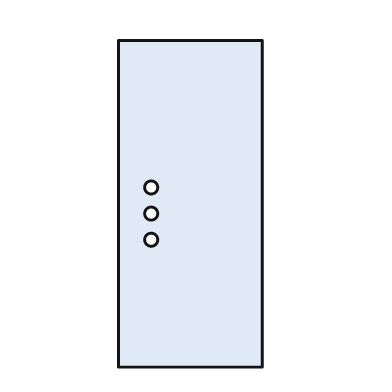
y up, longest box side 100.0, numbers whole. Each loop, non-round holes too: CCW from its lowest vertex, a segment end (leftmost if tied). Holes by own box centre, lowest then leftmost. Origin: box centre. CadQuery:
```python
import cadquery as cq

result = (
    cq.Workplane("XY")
    .moveTo(-22.0, -50.0)
    .lineTo(22.0, -50.0)
    .lineTo(22.0, 50.0)
    .lineTo(-22.0, 50.0)
    .close()
    .moveTo(-12.0, -11.0)
    .circle(2.0)
    .moveTo(-12.0, -3.0)
    .circle(2.0)
    .moveTo(-12.0, 5.0)
    .circle(2.0)
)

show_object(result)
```